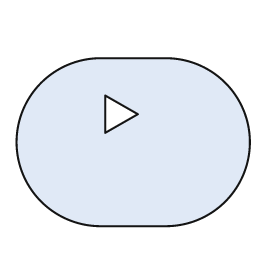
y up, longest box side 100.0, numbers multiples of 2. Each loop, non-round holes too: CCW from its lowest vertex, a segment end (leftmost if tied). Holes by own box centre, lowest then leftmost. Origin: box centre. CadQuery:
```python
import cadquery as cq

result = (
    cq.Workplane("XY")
    .moveTo(-14.0, -36.0)
    .lineTo(14.0, -36.0)
    .threePointArc((50.0, 0.0), (14.0, 36.0))
    .lineTo(-14.0, 36.0)
    .threePointArc((-50.0, 0.0), (-14.0, -36.0))
    .close()
    .moveTo(-12.0, 4.0)
    .lineTo(2.0, 12.0)
    .lineTo(-12.0, 20.0)
    .close()
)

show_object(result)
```